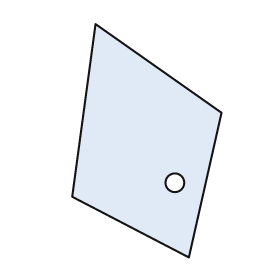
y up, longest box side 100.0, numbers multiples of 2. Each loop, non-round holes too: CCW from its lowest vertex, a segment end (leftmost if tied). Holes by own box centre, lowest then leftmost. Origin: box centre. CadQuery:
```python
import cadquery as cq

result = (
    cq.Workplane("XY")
    .moveTo(18.0, -50.0)
    .lineTo(32.0, 12.0)
    .lineTo(-22.0, 50.0)
    .lineTo(-32.0, -24.0)
    .close()
    .moveTo(12.0, -18.0)
    .circle(4.0)
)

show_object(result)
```